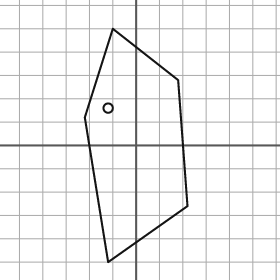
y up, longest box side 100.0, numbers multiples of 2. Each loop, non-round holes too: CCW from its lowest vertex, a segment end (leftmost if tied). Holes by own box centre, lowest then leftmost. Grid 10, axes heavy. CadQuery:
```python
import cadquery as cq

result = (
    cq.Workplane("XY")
    .moveTo(-12.0, -50.0)
    .lineTo(22.0, -26.0)
    .lineTo(18.0, 28.0)
    .lineTo(-10.0, 50.0)
    .lineTo(-22.0, 12.0)
    .close()
    .moveTo(-12.0, 16.0)
    .circle(2.0)
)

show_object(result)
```